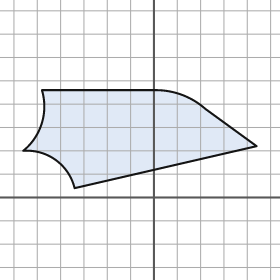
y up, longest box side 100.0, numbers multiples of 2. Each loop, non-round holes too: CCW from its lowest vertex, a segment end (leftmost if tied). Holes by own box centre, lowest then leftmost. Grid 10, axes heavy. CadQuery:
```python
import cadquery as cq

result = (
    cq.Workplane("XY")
    .moveTo(-34.0, 4.0)
    .lineTo(44.0, 22.0)
    .lineTo(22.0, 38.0)
    .threePointArc((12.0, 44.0), (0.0, 46.0))
    .lineTo(-48.0, 46.0)
    .threePointArc((-48.0, 32.0), (-56.0, 20.0))
    .threePointArc((-42.0, 16.0), (-34.0, 4.0))
    .close()
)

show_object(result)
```